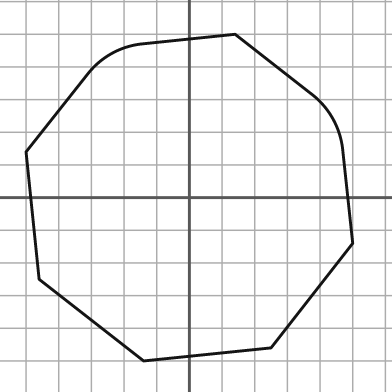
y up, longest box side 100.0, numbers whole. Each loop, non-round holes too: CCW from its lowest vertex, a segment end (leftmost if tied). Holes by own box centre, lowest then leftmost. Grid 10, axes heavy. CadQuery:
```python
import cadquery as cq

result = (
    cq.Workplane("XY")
    .moveTo(-14.0, -50.0)
    .lineTo(25.0, -46.0)
    .lineTo(50.0, -14.0)
    .lineTo(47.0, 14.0)
    .threePointArc((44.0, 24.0), (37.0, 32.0))
    .lineTo(14.0, 50.0)
    .lineTo(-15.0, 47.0)
    .threePointArc((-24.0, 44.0), (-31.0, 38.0))
    .lineTo(-50.0, 14.0)
    .lineTo(-46.0, -25.0)
    .close()
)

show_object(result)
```